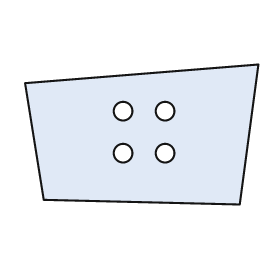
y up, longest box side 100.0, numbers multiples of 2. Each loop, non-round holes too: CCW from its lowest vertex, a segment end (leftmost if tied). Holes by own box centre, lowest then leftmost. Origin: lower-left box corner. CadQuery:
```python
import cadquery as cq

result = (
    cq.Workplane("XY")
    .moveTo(92.0, 0.0)
    .lineTo(100.0, 60.0)
    .lineTo(0.0, 52.0)
    .lineTo(8.0, 2.0)
    .close()
    .moveTo(42.0, 22.0)
    .circle(4.0)
    .moveTo(60.0, 22.0)
    .circle(4.0)
    .moveTo(42.0, 40.0)
    .circle(4.0)
    .moveTo(60.0, 40.0)
    .circle(4.0)
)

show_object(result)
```